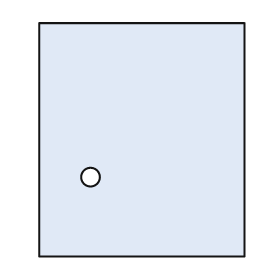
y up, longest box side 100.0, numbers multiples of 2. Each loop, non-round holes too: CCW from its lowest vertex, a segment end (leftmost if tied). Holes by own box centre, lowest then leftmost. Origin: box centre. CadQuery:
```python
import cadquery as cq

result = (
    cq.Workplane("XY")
    .moveTo(-44.0, -50.0)
    .lineTo(44.0, -50.0)
    .lineTo(44.0, 50.0)
    .lineTo(-44.0, 50.0)
    .close()
    .moveTo(-22.0, -16.0)
    .circle(4.0)
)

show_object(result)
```